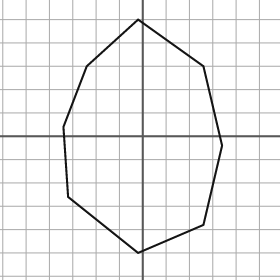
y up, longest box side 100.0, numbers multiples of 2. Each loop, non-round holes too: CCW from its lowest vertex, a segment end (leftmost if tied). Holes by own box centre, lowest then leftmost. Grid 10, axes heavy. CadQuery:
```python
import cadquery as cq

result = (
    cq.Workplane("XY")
    .moveTo(-2.0, -50.0)
    .lineTo(26.0, -38.0)
    .lineTo(34.0, -4.0)
    .lineTo(26.0, 30.0)
    .lineTo(-2.0, 50.0)
    .lineTo(-24.0, 30.0)
    .lineTo(-34.0, 4.0)
    .lineTo(-32.0, -26.0)
    .close()
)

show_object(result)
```